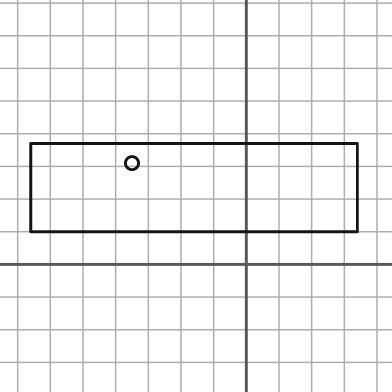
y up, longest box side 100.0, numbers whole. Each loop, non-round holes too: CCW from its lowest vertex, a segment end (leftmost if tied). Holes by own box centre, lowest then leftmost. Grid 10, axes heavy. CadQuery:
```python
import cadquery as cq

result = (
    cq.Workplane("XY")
    .moveTo(-66.0, 10.0)
    .lineTo(34.0, 10.0)
    .lineTo(34.0, 37.0)
    .lineTo(-66.0, 37.0)
    .close()
    .moveTo(-35.0, 31.0)
    .circle(2.0)
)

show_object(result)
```